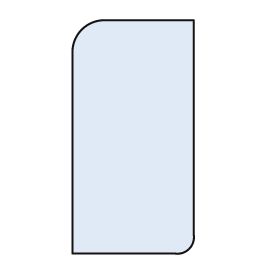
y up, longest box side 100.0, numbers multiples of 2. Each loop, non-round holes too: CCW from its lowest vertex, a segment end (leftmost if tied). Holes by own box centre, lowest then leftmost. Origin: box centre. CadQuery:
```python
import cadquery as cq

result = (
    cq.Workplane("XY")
    .moveTo(-26.0, -50.0)
    .lineTo(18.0, -50.0)
    .threePointArc((24.0, -48.0), (26.0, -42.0))
    .lineTo(26.0, 50.0)
    .lineTo(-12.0, 50.0)
    .threePointArc((-22.0, 46.0), (-26.0, 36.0))
    .close()
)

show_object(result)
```